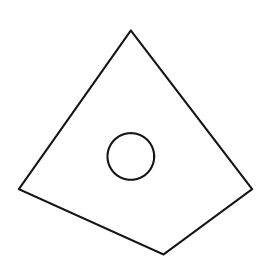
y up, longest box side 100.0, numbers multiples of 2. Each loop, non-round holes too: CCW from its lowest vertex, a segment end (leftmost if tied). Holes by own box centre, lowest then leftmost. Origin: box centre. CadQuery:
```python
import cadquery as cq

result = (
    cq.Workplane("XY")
    .moveTo(12.0, -48.0)
    .lineTo(50.0, -20.0)
    .lineTo(-2.0, 48.0)
    .lineTo(-50.0, -20.0)
    .close()
    .moveTo(-2.0, -6.0)
    .circle(10.0)
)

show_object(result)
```